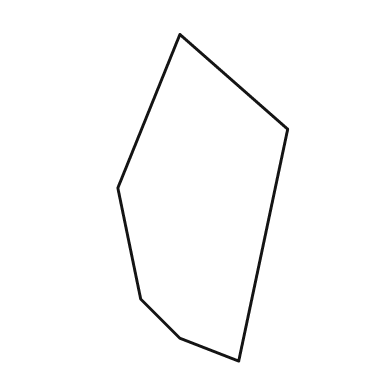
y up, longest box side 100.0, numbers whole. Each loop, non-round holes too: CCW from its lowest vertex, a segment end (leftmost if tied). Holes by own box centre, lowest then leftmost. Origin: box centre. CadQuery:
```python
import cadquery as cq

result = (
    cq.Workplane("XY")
    .moveTo(11.0, -50.0)
    .lineTo(26.0, 21.0)
    .lineTo(-7.0, 50.0)
    .lineTo(-26.0, 3.0)
    .lineTo(-19.0, -31.0)
    .lineTo(-7.0, -43.0)
    .close()
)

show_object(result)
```